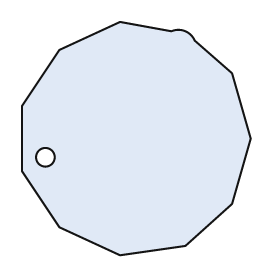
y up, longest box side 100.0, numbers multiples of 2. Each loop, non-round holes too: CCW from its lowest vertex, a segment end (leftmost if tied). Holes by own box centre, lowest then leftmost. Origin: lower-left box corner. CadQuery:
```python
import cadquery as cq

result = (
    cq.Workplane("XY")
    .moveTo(42.0, 0.0)
    .lineTo(70.0, 4.0)
    .lineTo(90.0, 22.0)
    .lineTo(98.0, 50.0)
    .lineTo(90.0, 78.0)
    .lineTo(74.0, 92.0)
    .threePointArc((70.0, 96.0), (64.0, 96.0))
    .lineTo(42.0, 100.0)
    .lineTo(16.0, 88.0)
    .lineTo(0.0, 64.0)
    .lineTo(0.0, 36.0)
    .lineTo(16.0, 12.0)
    .close()
    .moveTo(10.0, 42.0)
    .circle(4.0)
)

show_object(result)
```